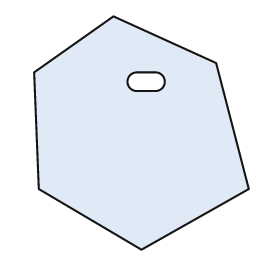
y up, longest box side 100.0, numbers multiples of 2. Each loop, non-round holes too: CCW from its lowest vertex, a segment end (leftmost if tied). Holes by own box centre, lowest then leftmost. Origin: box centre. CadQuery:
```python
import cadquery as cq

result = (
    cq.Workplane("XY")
    .moveTo(0.0, -50.0)
    .lineTo(46.0, -24.0)
    .lineTo(32.0, 30.0)
    .lineTo(-12.0, 50.0)
    .lineTo(-46.0, 26.0)
    .lineTo(-44.0, -24.0)
    .close()
    .moveTo(-2.0, 18.0)
    .lineTo(6.0, 18.0)
    .threePointArc((10.0, 22.0), (6.0, 26.0))
    .lineTo(-2.0, 26.0)
    .threePointArc((-6.0, 22.0), (-2.0, 18.0))
    .close()
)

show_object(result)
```